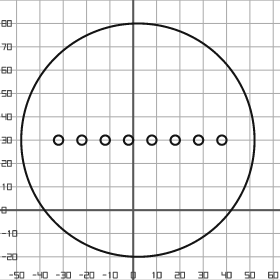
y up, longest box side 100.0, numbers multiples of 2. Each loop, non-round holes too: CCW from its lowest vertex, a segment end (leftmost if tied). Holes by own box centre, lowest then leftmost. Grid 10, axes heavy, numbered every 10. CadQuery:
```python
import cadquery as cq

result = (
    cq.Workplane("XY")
    .moveTo(2.0, 30.0)
    .circle(50.0)
    .moveTo(-32.0, 30.0)
    .circle(2.0)
    .moveTo(-22.0, 30.0)
    .circle(2.0)
    .moveTo(-12.0, 30.0)
    .circle(2.0)
    .moveTo(-2.0, 30.0)
    .circle(2.0)
    .moveTo(8.0, 30.0)
    .circle(2.0)
    .moveTo(18.0, 30.0)
    .circle(2.0)
    .moveTo(28.0, 30.0)
    .circle(2.0)
    .moveTo(38.0, 30.0)
    .circle(2.0)
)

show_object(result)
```